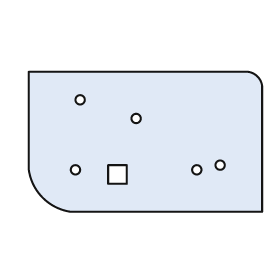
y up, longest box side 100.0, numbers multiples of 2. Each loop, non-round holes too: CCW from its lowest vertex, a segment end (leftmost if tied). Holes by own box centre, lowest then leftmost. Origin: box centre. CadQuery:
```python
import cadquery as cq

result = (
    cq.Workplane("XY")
    .moveTo(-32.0, -30.0)
    .lineTo(50.0, -30.0)
    .lineTo(50.0, 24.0)
    .threePointArc((48.0, 28.0), (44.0, 30.0))
    .lineTo(-50.0, 30.0)
    .lineTo(-50.0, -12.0)
    .threePointArc((-44.0, -24.0), (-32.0, -30.0))
    .close()
    .moveTo(-16.0, -18.0)
    .lineTo(-8.0, -18.0)
    .lineTo(-8.0, -10.0)
    .lineTo(-16.0, -10.0)
    .close()
    .moveTo(-30.0, -12.0)
    .circle(2.0)
    .moveTo(22.0, -12.0)
    .circle(2.0)
    .moveTo(32.0, -10.0)
    .circle(2.0)
    .moveTo(-4.0, 10.0)
    .circle(2.0)
    .moveTo(-28.0, 18.0)
    .circle(2.0)
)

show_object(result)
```